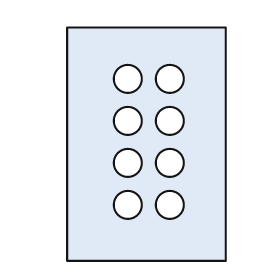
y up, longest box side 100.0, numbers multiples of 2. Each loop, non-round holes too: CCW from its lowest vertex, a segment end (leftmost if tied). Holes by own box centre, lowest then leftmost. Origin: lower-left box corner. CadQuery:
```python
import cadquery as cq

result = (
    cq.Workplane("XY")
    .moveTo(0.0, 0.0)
    .lineTo(68.0, 0.0)
    .lineTo(68.0, 100.0)
    .lineTo(0.0, 100.0)
    .close()
    .moveTo(26.0, 24.0)
    .circle(6.0)
    .moveTo(44.0, 24.0)
    .circle(6.0)
    .moveTo(26.0, 42.0)
    .circle(6.0)
    .moveTo(44.0, 42.0)
    .circle(6.0)
    .moveTo(26.0, 60.0)
    .circle(6.0)
    .moveTo(44.0, 60.0)
    .circle(6.0)
    .moveTo(26.0, 78.0)
    .circle(6.0)
    .moveTo(44.0, 78.0)
    .circle(6.0)
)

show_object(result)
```